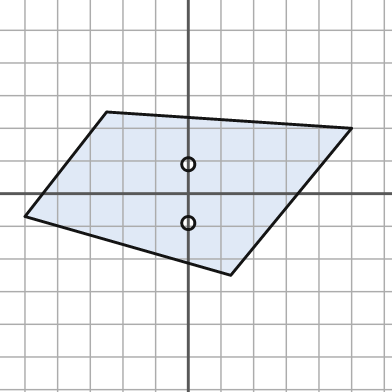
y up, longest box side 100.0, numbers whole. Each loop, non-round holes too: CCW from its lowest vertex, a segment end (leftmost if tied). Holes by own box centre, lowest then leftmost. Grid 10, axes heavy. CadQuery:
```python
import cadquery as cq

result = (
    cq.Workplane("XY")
    .moveTo(13.0, -25.0)
    .lineTo(50.0, 20.0)
    .lineTo(-25.0, 25.0)
    .lineTo(-50.0, -7.0)
    .close()
    .moveTo(0.0, -9.0)
    .circle(2.0)
    .moveTo(0.0, 9.0)
    .circle(2.0)
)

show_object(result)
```